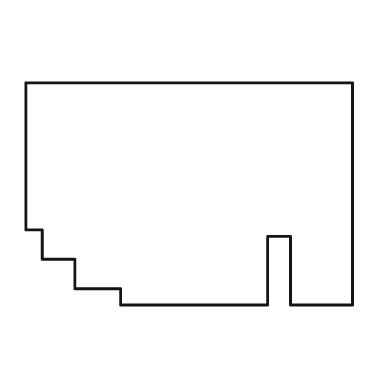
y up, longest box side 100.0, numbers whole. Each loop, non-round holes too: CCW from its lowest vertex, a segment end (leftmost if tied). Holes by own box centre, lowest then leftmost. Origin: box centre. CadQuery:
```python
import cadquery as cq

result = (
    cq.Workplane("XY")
    .moveTo(-21.0, -34.0)
    .lineTo(24.0, -34.0)
    .lineTo(24.0, -13.0)
    .lineTo(31.0, -13.0)
    .lineTo(31.0, -34.0)
    .lineTo(50.0, -34.0)
    .lineTo(50.0, 34.0)
    .lineTo(-50.0, 34.0)
    .lineTo(-50.0, -11.0)
    .lineTo(-45.0, -11.0)
    .lineTo(-45.0, -20.0)
    .lineTo(-35.0, -20.0)
    .lineTo(-35.0, -29.0)
    .lineTo(-21.0, -29.0)
    .close()
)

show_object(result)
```